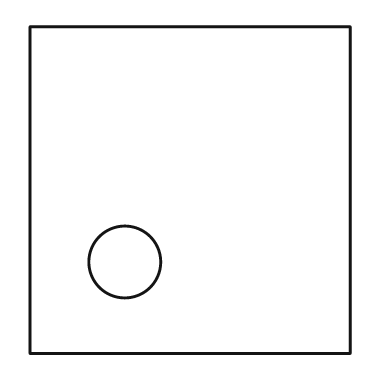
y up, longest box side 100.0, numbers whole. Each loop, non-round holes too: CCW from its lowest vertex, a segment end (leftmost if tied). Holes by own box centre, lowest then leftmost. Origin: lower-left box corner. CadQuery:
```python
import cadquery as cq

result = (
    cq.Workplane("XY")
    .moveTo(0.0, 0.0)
    .lineTo(98.0, 0.0)
    .lineTo(98.0, 100.0)
    .lineTo(0.0, 100.0)
    .close()
    .moveTo(29.0, 28.0)
    .circle(11.0)
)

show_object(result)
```